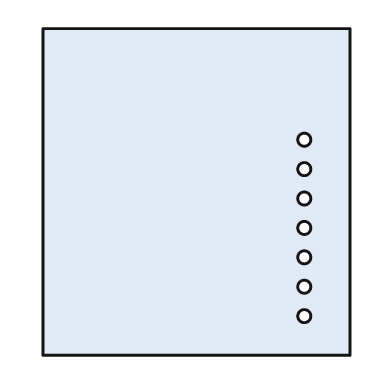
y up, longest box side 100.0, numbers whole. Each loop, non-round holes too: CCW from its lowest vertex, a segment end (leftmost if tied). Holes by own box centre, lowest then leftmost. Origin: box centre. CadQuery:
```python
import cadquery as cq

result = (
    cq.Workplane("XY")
    .moveTo(-47.0, -50.0)
    .lineTo(47.0, -50.0)
    .lineTo(47.0, 50.0)
    .lineTo(-47.0, 50.0)
    .close()
    .moveTo(33.0, -38.0)
    .circle(2.0)
    .moveTo(33.0, -29.0)
    .circle(2.0)
    .moveTo(33.0, -20.0)
    .circle(2.0)
    .moveTo(33.0, -11.0)
    .circle(2.0)
    .moveTo(33.0, -2.0)
    .circle(2.0)
    .moveTo(33.0, 7.0)
    .circle(2.0)
    .moveTo(33.0, 16.0)
    .circle(2.0)
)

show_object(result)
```